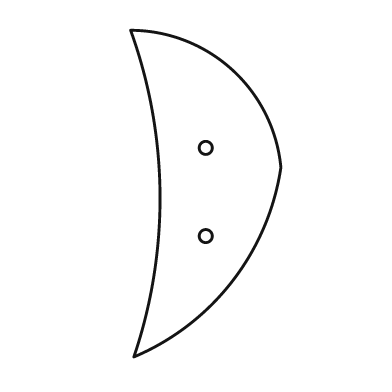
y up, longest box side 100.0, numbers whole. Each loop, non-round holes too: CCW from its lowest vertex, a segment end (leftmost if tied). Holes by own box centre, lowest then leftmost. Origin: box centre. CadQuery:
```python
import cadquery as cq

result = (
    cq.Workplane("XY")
    .moveTo(-22.0, -50.0)
    .threePointArc((8.0, -27.0), (23.0, 8.0))
    .threePointArc((8.0, 38.0), (-23.0, 50.0))
    .threePointArc((-14.0, 0.0), (-22.0, -50.0))
    .close()
    .moveTo(0.0, -13.0)
    .circle(2.0)
    .moveTo(0.0, 14.0)
    .circle(2.0)
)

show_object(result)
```